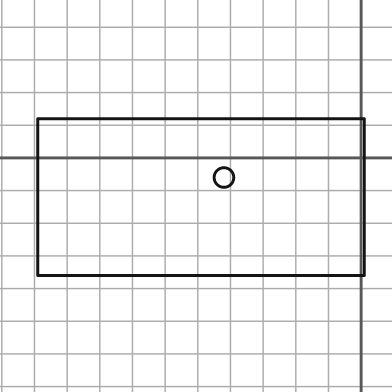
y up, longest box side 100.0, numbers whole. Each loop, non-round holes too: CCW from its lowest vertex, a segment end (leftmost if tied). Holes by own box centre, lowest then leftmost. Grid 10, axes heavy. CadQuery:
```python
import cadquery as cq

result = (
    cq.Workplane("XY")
    .moveTo(-99.0, -36.0)
    .lineTo(1.0, -36.0)
    .lineTo(1.0, 12.0)
    .lineTo(-99.0, 12.0)
    .close()
    .moveTo(-42.0, -6.0)
    .circle(3.0)
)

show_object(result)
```